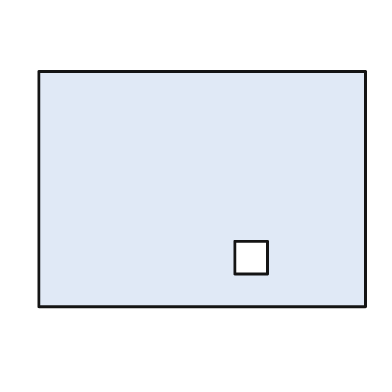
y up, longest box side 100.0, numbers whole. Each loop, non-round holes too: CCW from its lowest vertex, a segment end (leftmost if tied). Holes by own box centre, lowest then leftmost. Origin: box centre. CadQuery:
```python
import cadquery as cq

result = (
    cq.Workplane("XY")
    .moveTo(-50.0, -36.0)
    .lineTo(50.0, -36.0)
    .lineTo(50.0, 36.0)
    .lineTo(-50.0, 36.0)
    .close()
    .moveTo(10.0, -26.0)
    .lineTo(20.0, -26.0)
    .lineTo(20.0, -16.0)
    .lineTo(10.0, -16.0)
    .close()
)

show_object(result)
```